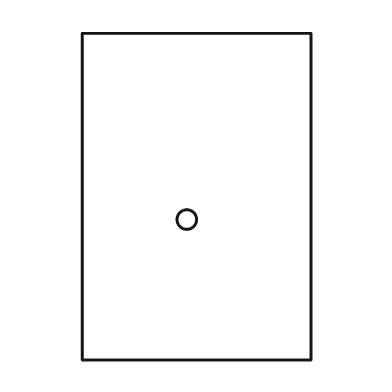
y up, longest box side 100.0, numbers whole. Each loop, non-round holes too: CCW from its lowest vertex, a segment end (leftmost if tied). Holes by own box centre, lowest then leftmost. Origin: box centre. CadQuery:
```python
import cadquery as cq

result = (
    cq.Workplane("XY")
    .moveTo(-35.0, -50.0)
    .lineTo(35.0, -50.0)
    .lineTo(35.0, 50.0)
    .lineTo(-35.0, 50.0)
    .close()
    .moveTo(-3.0, -7.0)
    .circle(3.0)
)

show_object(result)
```